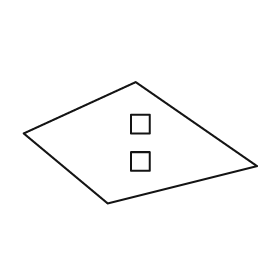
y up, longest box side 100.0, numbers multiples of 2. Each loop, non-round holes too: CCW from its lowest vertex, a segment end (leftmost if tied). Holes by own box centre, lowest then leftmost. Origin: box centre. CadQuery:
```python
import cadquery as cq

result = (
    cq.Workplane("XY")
    .moveTo(-14.0, -26.0)
    .lineTo(50.0, -10.0)
    .lineTo(-2.0, 26.0)
    .lineTo(-50.0, 4.0)
    .close()
    .moveTo(-4.0, -12.0)
    .lineTo(4.0, -12.0)
    .lineTo(4.0, -4.0)
    .lineTo(-4.0, -4.0)
    .close()
    .moveTo(-4.0, 4.0)
    .lineTo(4.0, 4.0)
    .lineTo(4.0, 12.0)
    .lineTo(-4.0, 12.0)
    .close()
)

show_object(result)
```